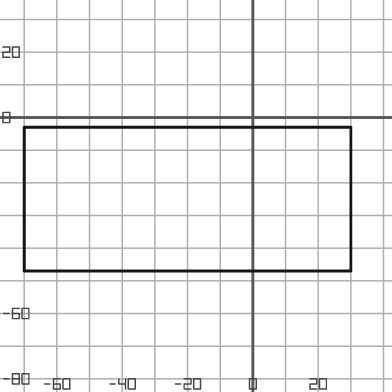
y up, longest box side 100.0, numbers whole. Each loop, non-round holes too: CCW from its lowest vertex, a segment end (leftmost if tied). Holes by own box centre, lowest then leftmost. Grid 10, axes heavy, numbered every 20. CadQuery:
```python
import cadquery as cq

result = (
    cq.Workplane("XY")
    .moveTo(-70.0, -47.0)
    .lineTo(30.0, -47.0)
    .lineTo(30.0, -3.0)
    .lineTo(-70.0, -3.0)
    .close()
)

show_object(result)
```